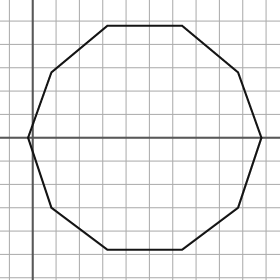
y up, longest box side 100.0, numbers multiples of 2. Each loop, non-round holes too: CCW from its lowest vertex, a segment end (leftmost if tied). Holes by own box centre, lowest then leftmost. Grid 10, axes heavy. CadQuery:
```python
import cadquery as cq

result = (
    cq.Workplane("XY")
    .moveTo(32.0, -48.0)
    .lineTo(64.0, -48.0)
    .lineTo(88.0, -30.0)
    .lineTo(98.0, 0.0)
    .lineTo(88.0, 28.0)
    .lineTo(64.0, 48.0)
    .lineTo(32.0, 48.0)
    .lineTo(8.0, 28.0)
    .lineTo(-2.0, 0.0)
    .lineTo(8.0, -30.0)
    .close()
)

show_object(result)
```